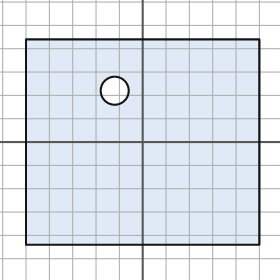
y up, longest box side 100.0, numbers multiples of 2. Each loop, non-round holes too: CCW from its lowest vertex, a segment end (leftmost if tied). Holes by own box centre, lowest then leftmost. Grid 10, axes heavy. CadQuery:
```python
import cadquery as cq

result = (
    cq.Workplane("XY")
    .moveTo(-50.0, -44.0)
    .lineTo(50.0, -44.0)
    .lineTo(50.0, 44.0)
    .lineTo(-50.0, 44.0)
    .close()
    .moveTo(-12.0, 22.0)
    .circle(6.0)
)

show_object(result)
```